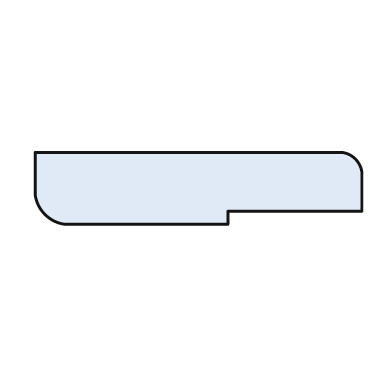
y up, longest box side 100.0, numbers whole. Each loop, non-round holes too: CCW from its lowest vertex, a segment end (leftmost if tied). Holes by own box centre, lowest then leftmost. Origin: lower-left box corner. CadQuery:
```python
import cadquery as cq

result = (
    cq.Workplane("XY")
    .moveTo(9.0, 0.0)
    .lineTo(59.0, 0.0)
    .lineTo(59.0, 4.0)
    .lineTo(100.0, 4.0)
    .lineTo(100.0, 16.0)
    .threePointArc((98.0, 20.0), (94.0, 22.0))
    .lineTo(0.0, 22.0)
    .lineTo(0.0, 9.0)
    .threePointArc((3.0, 3.0), (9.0, 0.0))
    .close()
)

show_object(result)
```